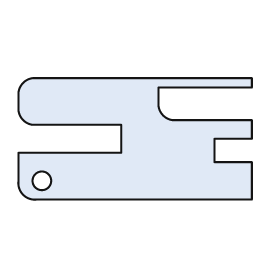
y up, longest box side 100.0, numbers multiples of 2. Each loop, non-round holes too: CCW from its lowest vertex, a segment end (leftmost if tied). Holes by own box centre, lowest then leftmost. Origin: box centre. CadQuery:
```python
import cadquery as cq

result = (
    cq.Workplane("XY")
    .moveTo(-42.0, -26.0)
    .lineTo(50.0, -26.0)
    .lineTo(50.0, -10.0)
    .lineTo(34.0, -10.0)
    .lineTo(34.0, 0.0)
    .lineTo(50.0, 0.0)
    .lineTo(50.0, 8.0)
    .lineTo(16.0, 8.0)
    .threePointArc((12.0, 10.0), (10.0, 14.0))
    .lineTo(10.0, 22.0)
    .lineTo(50.0, 22.0)
    .lineTo(50.0, 26.0)
    .lineTo(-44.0, 26.0)
    .threePointArc((-48.0, 24.0), (-50.0, 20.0))
    .lineTo(-50.0, 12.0)
    .threePointArc((-48.0, 8.0), (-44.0, 6.0))
    .lineTo(-6.0, 6.0)
    .lineTo(-6.0, -6.0)
    .lineTo(-50.0, -6.0)
    .lineTo(-50.0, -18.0)
    .threePointArc((-48.0, -24.0), (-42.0, -26.0))
    .close()
    .moveTo(-40.0, -18.0)
    .circle(4.0)
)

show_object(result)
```